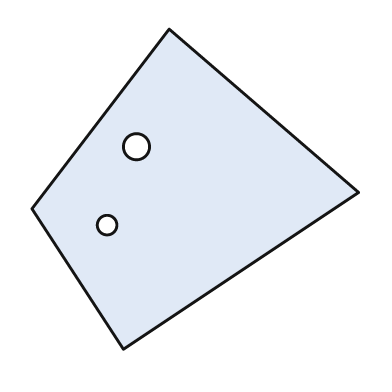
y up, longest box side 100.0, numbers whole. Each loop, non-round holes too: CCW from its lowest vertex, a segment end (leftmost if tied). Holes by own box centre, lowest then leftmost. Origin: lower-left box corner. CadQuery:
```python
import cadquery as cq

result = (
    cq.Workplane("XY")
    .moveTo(28.0, 0.0)
    .lineTo(100.0, 48.0)
    .lineTo(42.0, 98.0)
    .lineTo(0.0, 43.0)
    .close()
    .moveTo(23.0, 38.0)
    .circle(3.0)
    .moveTo(32.0, 62.0)
    .circle(4.0)
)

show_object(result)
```